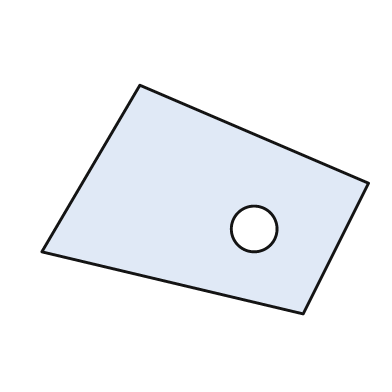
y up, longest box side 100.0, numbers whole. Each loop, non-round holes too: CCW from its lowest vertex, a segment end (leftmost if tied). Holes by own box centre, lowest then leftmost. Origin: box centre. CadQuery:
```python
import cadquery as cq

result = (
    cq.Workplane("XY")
    .moveTo(30.0, -35.0)
    .lineTo(50.0, 5.0)
    .lineTo(-20.0, 35.0)
    .lineTo(-50.0, -16.0)
    .close()
    .moveTo(15.0, -9.0)
    .circle(7.0)
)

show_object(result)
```